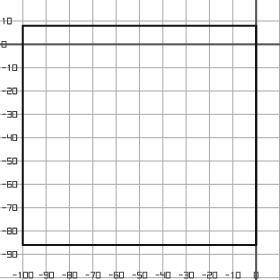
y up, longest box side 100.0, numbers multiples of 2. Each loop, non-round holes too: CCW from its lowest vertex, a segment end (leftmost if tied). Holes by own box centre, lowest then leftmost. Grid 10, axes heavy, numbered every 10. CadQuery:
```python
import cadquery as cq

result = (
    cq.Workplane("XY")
    .moveTo(-100.0, -86.0)
    .lineTo(0.0, -86.0)
    .lineTo(0.0, 8.0)
    .lineTo(-100.0, 8.0)
    .close()
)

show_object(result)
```